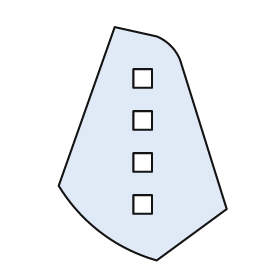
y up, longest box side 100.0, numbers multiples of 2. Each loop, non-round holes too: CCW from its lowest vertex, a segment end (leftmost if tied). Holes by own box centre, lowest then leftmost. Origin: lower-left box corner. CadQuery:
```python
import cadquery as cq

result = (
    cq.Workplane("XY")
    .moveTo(42.0, 0.0)
    .lineTo(72.0, 22.0)
    .lineTo(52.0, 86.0)
    .threePointArc((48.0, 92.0), (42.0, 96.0))
    .lineTo(24.0, 100.0)
    .lineTo(0.0, 32.0)
    .threePointArc((18.0, 12.0), (42.0, 0.0))
    .close()
    .moveTo(32.0, 20.0)
    .lineTo(40.0, 20.0)
    .lineTo(40.0, 28.0)
    .lineTo(32.0, 28.0)
    .close()
    .moveTo(32.0, 38.0)
    .lineTo(40.0, 38.0)
    .lineTo(40.0, 46.0)
    .lineTo(32.0, 46.0)
    .close()
    .moveTo(32.0, 56.0)
    .lineTo(40.0, 56.0)
    .lineTo(40.0, 64.0)
    .lineTo(32.0, 64.0)
    .close()
    .moveTo(32.0, 74.0)
    .lineTo(40.0, 74.0)
    .lineTo(40.0, 82.0)
    .lineTo(32.0, 82.0)
    .close()
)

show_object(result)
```